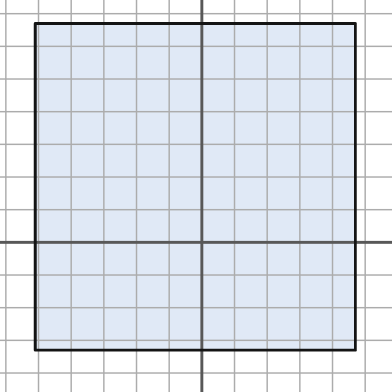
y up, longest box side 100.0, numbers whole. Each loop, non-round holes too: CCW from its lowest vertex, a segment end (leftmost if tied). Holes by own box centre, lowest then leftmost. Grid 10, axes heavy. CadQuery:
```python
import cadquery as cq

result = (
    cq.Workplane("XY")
    .moveTo(-51.0, -33.0)
    .lineTo(47.0, -33.0)
    .lineTo(47.0, 67.0)
    .lineTo(-51.0, 67.0)
    .close()
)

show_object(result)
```